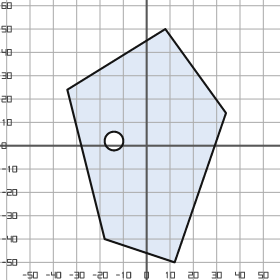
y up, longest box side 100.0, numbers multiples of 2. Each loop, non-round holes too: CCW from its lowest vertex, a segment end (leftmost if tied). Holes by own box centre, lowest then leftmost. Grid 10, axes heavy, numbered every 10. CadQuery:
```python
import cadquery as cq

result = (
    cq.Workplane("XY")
    .moveTo(12.0, -50.0)
    .lineTo(34.0, 14.0)
    .lineTo(8.0, 50.0)
    .lineTo(-34.0, 24.0)
    .lineTo(-18.0, -40.0)
    .close()
    .moveTo(-14.0, 2.0)
    .circle(4.0)
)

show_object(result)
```